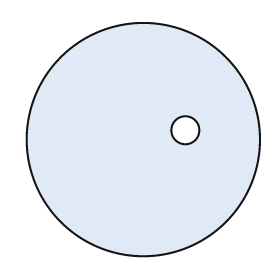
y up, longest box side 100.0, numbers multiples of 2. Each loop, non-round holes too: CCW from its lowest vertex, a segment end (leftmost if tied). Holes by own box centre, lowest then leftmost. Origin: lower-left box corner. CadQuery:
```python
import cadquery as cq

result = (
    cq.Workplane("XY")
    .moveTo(50.0, 50.0)
    .circle(50.0)
    .moveTo(68.0, 54.0)
    .circle(6.0)
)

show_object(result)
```